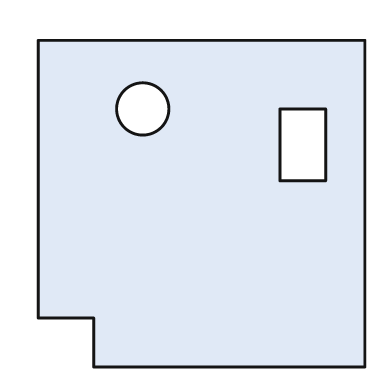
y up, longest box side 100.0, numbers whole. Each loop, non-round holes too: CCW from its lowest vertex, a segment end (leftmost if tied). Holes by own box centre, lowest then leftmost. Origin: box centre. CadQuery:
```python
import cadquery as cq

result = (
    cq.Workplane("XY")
    .moveTo(-33.0, -50.0)
    .lineTo(50.0, -50.0)
    .lineTo(50.0, 50.0)
    .lineTo(-50.0, 50.0)
    .lineTo(-50.0, -35.0)
    .lineTo(-33.0, -35.0)
    .close()
    .moveTo(24.0, 7.0)
    .lineTo(38.0, 7.0)
    .lineTo(38.0, 29.0)
    .lineTo(24.0, 29.0)
    .close()
    .moveTo(-18.0, 29.0)
    .circle(8.0)
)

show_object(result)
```